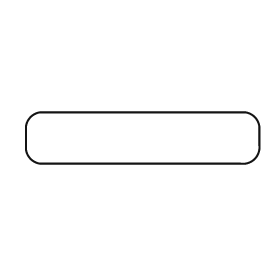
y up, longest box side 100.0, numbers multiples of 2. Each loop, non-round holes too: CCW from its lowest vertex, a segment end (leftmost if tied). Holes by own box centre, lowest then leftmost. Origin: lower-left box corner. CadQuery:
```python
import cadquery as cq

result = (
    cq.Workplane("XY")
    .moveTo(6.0, 0.0)
    .lineTo(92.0, 0.0)
    .threePointArc((98.0, 2.0), (100.0, 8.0))
    .lineTo(100.0, 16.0)
    .threePointArc((98.0, 20.0), (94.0, 22.0))
    .lineTo(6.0, 22.0)
    .threePointArc((2.0, 20.0), (0.0, 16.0))
    .lineTo(0.0, 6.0)
    .threePointArc((2.0, 2.0), (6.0, 0.0))
    .close()
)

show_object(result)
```